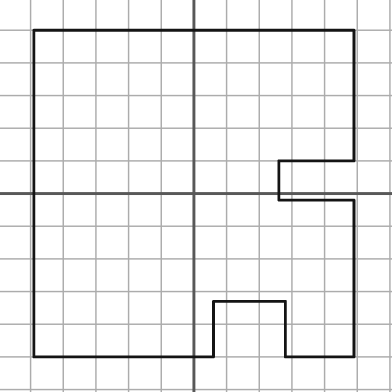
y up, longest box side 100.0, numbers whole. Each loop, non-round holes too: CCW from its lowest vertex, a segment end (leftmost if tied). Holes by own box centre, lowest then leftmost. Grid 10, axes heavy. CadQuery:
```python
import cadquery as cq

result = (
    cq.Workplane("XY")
    .moveTo(-49.0, -50.0)
    .lineTo(6.0, -50.0)
    .lineTo(6.0, -33.0)
    .lineTo(28.0, -33.0)
    .lineTo(28.0, -50.0)
    .lineTo(49.0, -50.0)
    .lineTo(49.0, -2.0)
    .lineTo(26.0, -2.0)
    .lineTo(26.0, 10.0)
    .lineTo(49.0, 10.0)
    .lineTo(49.0, 50.0)
    .lineTo(-49.0, 50.0)
    .close()
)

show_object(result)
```